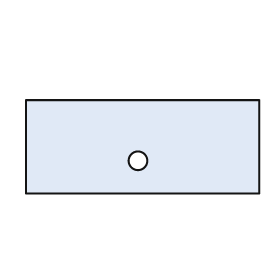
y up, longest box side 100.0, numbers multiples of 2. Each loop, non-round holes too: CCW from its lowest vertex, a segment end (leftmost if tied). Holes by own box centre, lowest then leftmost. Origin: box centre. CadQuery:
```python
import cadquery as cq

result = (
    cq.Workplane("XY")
    .moveTo(-50.0, -20.0)
    .lineTo(50.0, -20.0)
    .lineTo(50.0, 20.0)
    .lineTo(-50.0, 20.0)
    .close()
    .moveTo(-2.0, -6.0)
    .circle(4.0)
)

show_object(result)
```